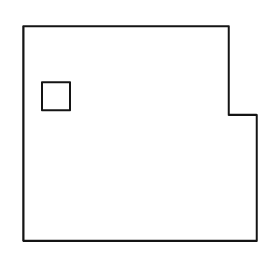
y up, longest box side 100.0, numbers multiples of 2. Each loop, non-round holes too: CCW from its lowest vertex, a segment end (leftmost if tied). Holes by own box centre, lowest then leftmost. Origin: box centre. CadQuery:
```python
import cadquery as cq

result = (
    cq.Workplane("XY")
    .moveTo(-50.0, -46.0)
    .lineTo(50.0, -46.0)
    .lineTo(50.0, 8.0)
    .lineTo(38.0, 8.0)
    .lineTo(38.0, 46.0)
    .lineTo(-50.0, 46.0)
    .close()
    .moveTo(-42.0, 10.0)
    .lineTo(-30.0, 10.0)
    .lineTo(-30.0, 22.0)
    .lineTo(-42.0, 22.0)
    .close()
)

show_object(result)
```